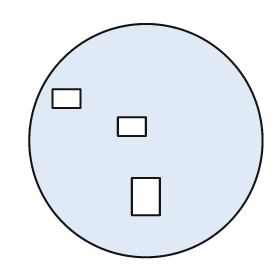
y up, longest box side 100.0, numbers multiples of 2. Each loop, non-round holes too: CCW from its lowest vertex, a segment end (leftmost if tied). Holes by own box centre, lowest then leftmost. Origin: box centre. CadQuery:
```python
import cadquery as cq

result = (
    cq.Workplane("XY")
    .moveTo(0.0, 0.0)
    .circle(50.0)
    .moveTo(-6.0, -32.0)
    .lineTo(6.0, -32.0)
    .lineTo(6.0, -16.0)
    .lineTo(-6.0, -16.0)
    .close()
    .moveTo(-12.0, 2.0)
    .lineTo(0.0, 2.0)
    .lineTo(0.0, 10.0)
    .lineTo(-12.0, 10.0)
    .close()
    .moveTo(-40.0, 14.0)
    .lineTo(-28.0, 14.0)
    .lineTo(-28.0, 22.0)
    .lineTo(-40.0, 22.0)
    .close()
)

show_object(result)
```